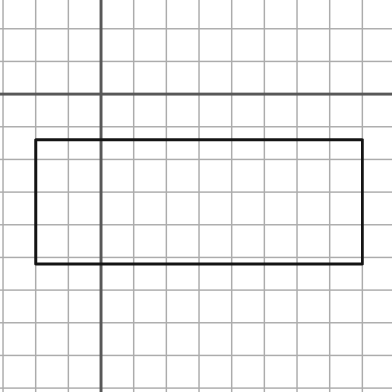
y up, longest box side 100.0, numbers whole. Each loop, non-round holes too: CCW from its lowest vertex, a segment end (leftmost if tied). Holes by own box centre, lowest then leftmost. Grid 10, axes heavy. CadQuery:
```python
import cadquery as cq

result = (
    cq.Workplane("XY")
    .moveTo(-20.0, -52.0)
    .lineTo(80.0, -52.0)
    .lineTo(80.0, -14.0)
    .lineTo(-20.0, -14.0)
    .close()
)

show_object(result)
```